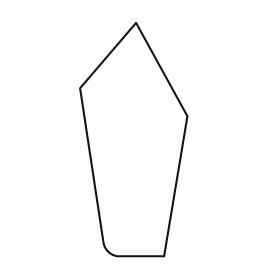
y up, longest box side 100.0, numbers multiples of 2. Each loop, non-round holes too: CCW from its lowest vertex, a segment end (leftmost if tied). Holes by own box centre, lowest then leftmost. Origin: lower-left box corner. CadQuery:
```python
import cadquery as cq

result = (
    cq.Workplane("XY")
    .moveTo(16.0, 0.0)
    .lineTo(36.0, 0.0)
    .lineTo(46.0, 60.0)
    .lineTo(24.0, 100.0)
    .lineTo(0.0, 72.0)
    .lineTo(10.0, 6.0)
    .threePointArc((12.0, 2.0), (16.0, 0.0))
    .close()
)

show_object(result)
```